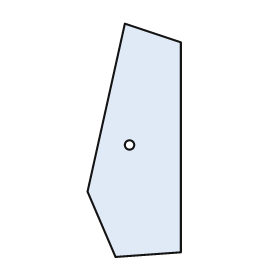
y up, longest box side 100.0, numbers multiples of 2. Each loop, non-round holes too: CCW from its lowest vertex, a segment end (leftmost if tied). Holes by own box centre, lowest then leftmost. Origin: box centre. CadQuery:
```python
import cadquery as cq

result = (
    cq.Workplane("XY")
    .moveTo(-8.0, -50.0)
    .lineTo(20.0, -48.0)
    .lineTo(20.0, 42.0)
    .lineTo(-4.0, 50.0)
    .lineTo(-20.0, -22.0)
    .close()
    .moveTo(-2.0, -2.0)
    .circle(2.0)
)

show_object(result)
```